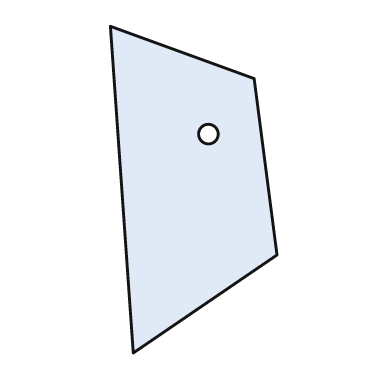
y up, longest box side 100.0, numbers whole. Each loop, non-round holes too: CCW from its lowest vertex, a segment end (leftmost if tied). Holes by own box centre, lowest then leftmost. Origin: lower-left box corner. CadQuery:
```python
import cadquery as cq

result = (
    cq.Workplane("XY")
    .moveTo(7.0, 0.0)
    .lineTo(51.0, 30.0)
    .lineTo(44.0, 84.0)
    .lineTo(0.0, 100.0)
    .close()
    .moveTo(30.0, 67.0)
    .circle(3.0)
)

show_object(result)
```